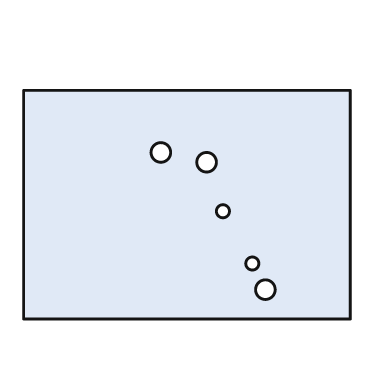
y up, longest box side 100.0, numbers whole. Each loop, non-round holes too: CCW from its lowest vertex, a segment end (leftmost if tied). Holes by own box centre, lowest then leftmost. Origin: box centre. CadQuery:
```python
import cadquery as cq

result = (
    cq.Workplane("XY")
    .moveTo(-50.0, -35.0)
    .lineTo(50.0, -35.0)
    .lineTo(50.0, 35.0)
    .lineTo(-50.0, 35.0)
    .close()
    .moveTo(24.0, -26.0)
    .circle(3.0)
    .moveTo(20.0, -18.0)
    .circle(2.0)
    .moveTo(11.0, -2.0)
    .circle(2.0)
    .moveTo(6.0, 13.0)
    .circle(3.0)
    .moveTo(-8.0, 16.0)
    .circle(3.0)
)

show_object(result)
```